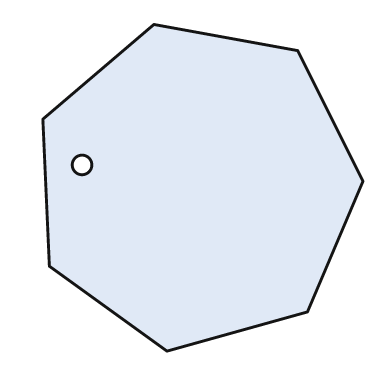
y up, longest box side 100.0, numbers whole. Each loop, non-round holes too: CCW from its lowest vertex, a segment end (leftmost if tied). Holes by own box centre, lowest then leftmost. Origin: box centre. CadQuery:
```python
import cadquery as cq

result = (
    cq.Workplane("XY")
    .moveTo(-11.0, -50.0)
    .lineTo(32.0, -38.0)
    .lineTo(49.0, 2.0)
    .lineTo(29.0, 42.0)
    .lineTo(-15.0, 50.0)
    .lineTo(-49.0, 21.0)
    .lineTo(-47.0, -24.0)
    .close()
    .moveTo(-37.0, 7.0)
    .circle(3.0)
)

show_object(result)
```